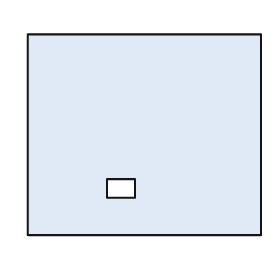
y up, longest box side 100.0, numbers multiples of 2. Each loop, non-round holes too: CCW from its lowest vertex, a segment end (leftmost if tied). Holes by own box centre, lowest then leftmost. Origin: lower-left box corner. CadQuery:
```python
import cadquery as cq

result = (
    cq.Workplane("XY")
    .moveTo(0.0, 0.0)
    .lineTo(100.0, 0.0)
    .lineTo(100.0, 86.0)
    .lineTo(0.0, 86.0)
    .close()
    .moveTo(34.0, 16.0)
    .lineTo(46.0, 16.0)
    .lineTo(46.0, 24.0)
    .lineTo(34.0, 24.0)
    .close()
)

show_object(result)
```